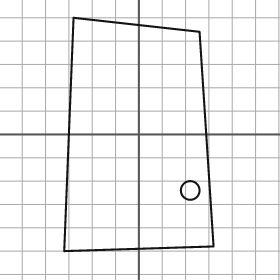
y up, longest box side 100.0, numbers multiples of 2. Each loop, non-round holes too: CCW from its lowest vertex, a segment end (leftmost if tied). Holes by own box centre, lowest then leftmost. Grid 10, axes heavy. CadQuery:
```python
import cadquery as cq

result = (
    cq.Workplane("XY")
    .moveTo(-32.0, -50.0)
    .lineTo(32.0, -48.0)
    .lineTo(26.0, 44.0)
    .lineTo(-28.0, 50.0)
    .close()
    .moveTo(22.0, -24.0)
    .circle(4.0)
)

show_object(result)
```